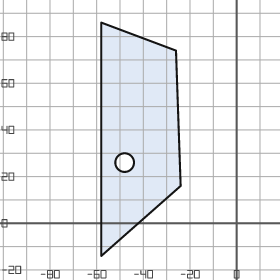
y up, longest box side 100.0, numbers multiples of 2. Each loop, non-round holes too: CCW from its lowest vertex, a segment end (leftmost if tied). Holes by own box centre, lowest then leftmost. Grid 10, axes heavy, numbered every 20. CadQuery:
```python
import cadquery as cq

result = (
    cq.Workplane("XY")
    .moveTo(-58.0, -14.0)
    .lineTo(-24.0, 16.0)
    .lineTo(-26.0, 74.0)
    .lineTo(-58.0, 86.0)
    .close()
    .moveTo(-48.0, 26.0)
    .circle(4.0)
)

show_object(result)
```